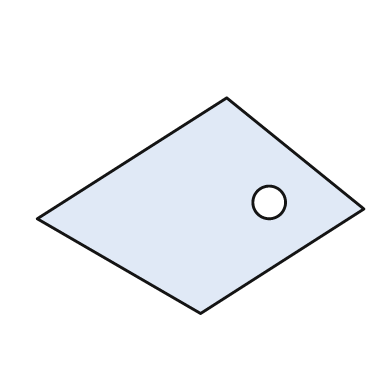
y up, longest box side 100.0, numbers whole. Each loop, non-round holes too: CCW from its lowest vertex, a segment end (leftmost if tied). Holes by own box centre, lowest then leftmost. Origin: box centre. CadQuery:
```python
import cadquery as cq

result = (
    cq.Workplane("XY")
    .moveTo(0.0, -33.0)
    .lineTo(50.0, -1.0)
    .lineTo(8.0, 33.0)
    .lineTo(-50.0, -4.0)
    .close()
    .moveTo(21.0, 1.0)
    .circle(5.0)
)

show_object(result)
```